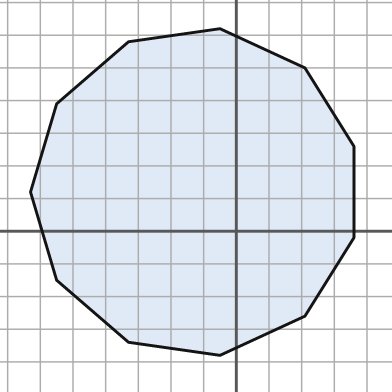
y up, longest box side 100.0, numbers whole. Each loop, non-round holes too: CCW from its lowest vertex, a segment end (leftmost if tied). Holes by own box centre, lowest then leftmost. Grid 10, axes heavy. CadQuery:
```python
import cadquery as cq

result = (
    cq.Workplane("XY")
    .moveTo(-5.0, -38.0)
    .lineTo(21.0, -26.0)
    .lineTo(36.0, -2.0)
    .lineTo(36.0, 26.0)
    .lineTo(21.0, 50.0)
    .lineTo(-5.0, 62.0)
    .lineTo(-33.0, 58.0)
    .lineTo(-55.0, 39.0)
    .lineTo(-63.0, 12.0)
    .lineTo(-55.0, -15.0)
    .lineTo(-33.0, -34.0)
    .close()
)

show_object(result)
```